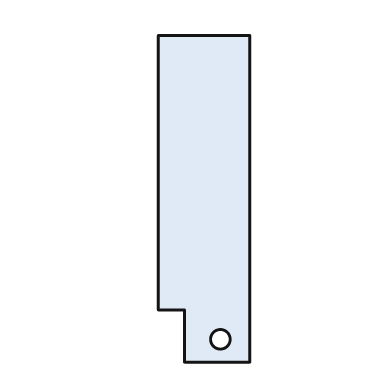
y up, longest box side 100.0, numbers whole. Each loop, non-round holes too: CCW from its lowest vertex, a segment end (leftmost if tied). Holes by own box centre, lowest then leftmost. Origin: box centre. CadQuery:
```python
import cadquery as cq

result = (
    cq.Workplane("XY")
    .moveTo(-6.0, -50.0)
    .lineTo(14.0, -50.0)
    .lineTo(14.0, 50.0)
    .lineTo(-14.0, 50.0)
    .lineTo(-14.0, -34.0)
    .lineTo(-6.0, -34.0)
    .close()
    .moveTo(5.0, -43.0)
    .circle(3.0)
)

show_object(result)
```